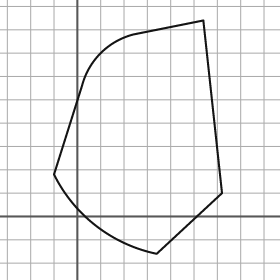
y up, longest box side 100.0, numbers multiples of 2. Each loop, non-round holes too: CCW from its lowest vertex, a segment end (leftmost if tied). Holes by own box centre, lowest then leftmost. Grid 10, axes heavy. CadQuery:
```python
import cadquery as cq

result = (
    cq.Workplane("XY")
    .moveTo(34.0, -16.0)
    .lineTo(62.0, 10.0)
    .lineTo(54.0, 84.0)
    .lineTo(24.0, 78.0)
    .threePointArc((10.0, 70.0), (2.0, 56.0))
    .lineTo(-10.0, 18.0)
    .threePointArc((8.0, -4.0), (34.0, -16.0))
    .close()
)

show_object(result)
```